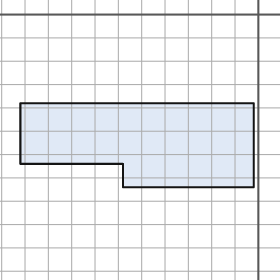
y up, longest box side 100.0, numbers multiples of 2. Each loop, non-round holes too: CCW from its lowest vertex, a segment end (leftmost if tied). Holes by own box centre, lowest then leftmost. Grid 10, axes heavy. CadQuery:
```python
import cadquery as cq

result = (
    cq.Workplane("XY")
    .moveTo(-58.0, -74.0)
    .lineTo(-2.0, -74.0)
    .lineTo(-2.0, -38.0)
    .lineTo(-102.0, -38.0)
    .lineTo(-102.0, -64.0)
    .lineTo(-58.0, -64.0)
    .close()
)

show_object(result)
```